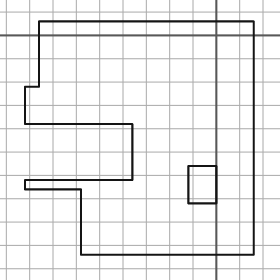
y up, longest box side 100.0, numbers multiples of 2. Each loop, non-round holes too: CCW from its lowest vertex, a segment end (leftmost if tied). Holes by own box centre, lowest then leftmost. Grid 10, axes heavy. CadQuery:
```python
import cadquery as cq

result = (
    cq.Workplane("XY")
    .moveTo(-58.0, -94.0)
    .lineTo(16.0, -94.0)
    .lineTo(16.0, 6.0)
    .lineTo(-76.0, 6.0)
    .lineTo(-76.0, -22.0)
    .lineTo(-82.0, -22.0)
    .lineTo(-82.0, -38.0)
    .lineTo(-36.0, -38.0)
    .lineTo(-36.0, -62.0)
    .lineTo(-82.0, -62.0)
    .lineTo(-82.0, -66.0)
    .lineTo(-58.0, -66.0)
    .close()
    .moveTo(-12.0, -72.0)
    .lineTo(0.0, -72.0)
    .lineTo(0.0, -56.0)
    .lineTo(-12.0, -56.0)
    .close()
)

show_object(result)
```